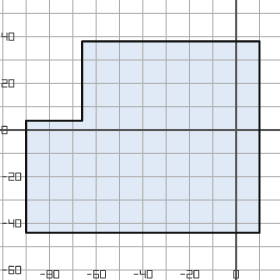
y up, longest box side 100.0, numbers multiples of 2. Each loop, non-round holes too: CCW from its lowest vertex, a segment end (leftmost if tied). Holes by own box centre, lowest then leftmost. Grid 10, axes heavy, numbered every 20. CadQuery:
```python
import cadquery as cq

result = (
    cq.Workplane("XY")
    .moveTo(-90.0, -44.0)
    .lineTo(10.0, -44.0)
    .lineTo(10.0, 38.0)
    .lineTo(-66.0, 38.0)
    .lineTo(-66.0, 4.0)
    .lineTo(-90.0, 4.0)
    .close()
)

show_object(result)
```